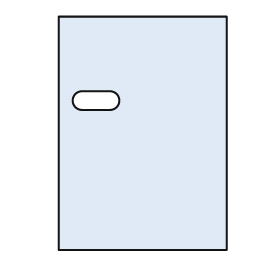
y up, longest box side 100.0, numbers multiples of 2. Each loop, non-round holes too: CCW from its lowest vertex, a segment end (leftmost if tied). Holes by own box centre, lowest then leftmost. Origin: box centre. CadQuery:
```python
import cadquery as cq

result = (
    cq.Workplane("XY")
    .moveTo(-36.0, -50.0)
    .lineTo(36.0, -50.0)
    .lineTo(36.0, 50.0)
    .lineTo(-36.0, 50.0)
    .close()
    .moveTo(-26.0, 10.0)
    .lineTo(-14.0, 10.0)
    .threePointArc((-10.0, 14.0), (-14.0, 18.0))
    .lineTo(-26.0, 18.0)
    .threePointArc((-30.0, 14.0), (-26.0, 10.0))
    .close()
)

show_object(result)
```